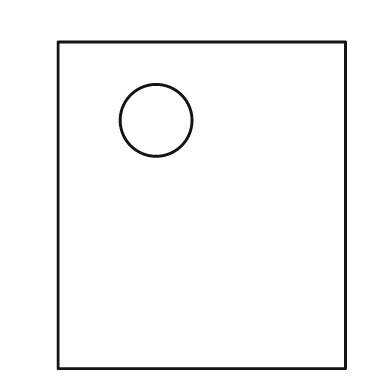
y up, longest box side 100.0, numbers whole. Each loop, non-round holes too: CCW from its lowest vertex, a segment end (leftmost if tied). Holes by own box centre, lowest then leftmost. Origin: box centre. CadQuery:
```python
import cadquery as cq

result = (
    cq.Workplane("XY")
    .moveTo(-44.0, -50.0)
    .lineTo(44.0, -50.0)
    .lineTo(44.0, 50.0)
    .lineTo(-44.0, 50.0)
    .close()
    .moveTo(-14.0, 26.0)
    .circle(11.0)
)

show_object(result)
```